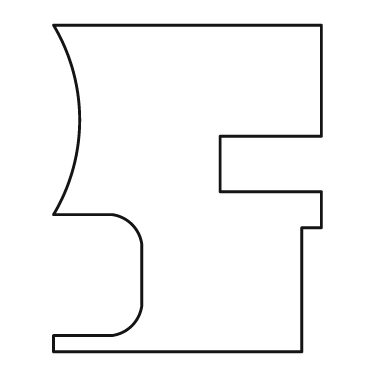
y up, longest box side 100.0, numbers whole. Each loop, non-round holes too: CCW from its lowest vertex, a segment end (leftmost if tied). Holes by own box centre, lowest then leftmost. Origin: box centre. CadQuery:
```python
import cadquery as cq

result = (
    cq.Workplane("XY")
    .moveTo(-41.0, -50.0)
    .lineTo(35.0, -50.0)
    .lineTo(35.0, -12.0)
    .lineTo(41.0, -12.0)
    .lineTo(41.0, -1.0)
    .lineTo(10.0, -1.0)
    .lineTo(10.0, 16.0)
    .lineTo(41.0, 16.0)
    .lineTo(41.0, 50.0)
    .lineTo(-41.0, 50.0)
    .threePointArc((-33.0, 21.0), (-41.0, -8.0))
    .lineTo(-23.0, -8.0)
    .threePointArc((-17.0, -11.0), (-14.0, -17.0))
    .lineTo(-14.0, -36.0)
    .threePointArc((-17.0, -42.0), (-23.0, -45.0))
    .lineTo(-41.0, -45.0)
    .close()
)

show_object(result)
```